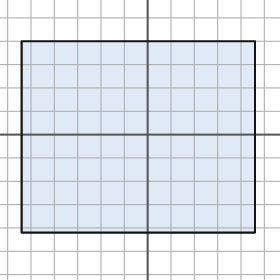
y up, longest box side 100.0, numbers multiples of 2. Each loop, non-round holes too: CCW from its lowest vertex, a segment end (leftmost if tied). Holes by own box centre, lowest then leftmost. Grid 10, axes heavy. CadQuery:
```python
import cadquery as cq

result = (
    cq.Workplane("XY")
    .moveTo(-54.0, -42.0)
    .lineTo(46.0, -42.0)
    .lineTo(46.0, 40.0)
    .lineTo(-54.0, 40.0)
    .close()
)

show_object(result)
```